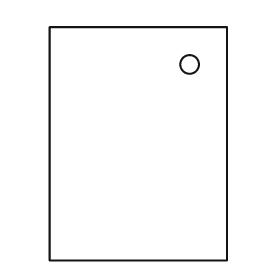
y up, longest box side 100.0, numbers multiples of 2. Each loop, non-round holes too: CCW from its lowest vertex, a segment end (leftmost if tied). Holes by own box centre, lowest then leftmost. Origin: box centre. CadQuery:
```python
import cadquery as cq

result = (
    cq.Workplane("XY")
    .moveTo(-38.0, -50.0)
    .lineTo(38.0, -50.0)
    .lineTo(38.0, 50.0)
    .lineTo(-38.0, 50.0)
    .close()
    .moveTo(22.0, 34.0)
    .circle(4.0)
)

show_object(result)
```